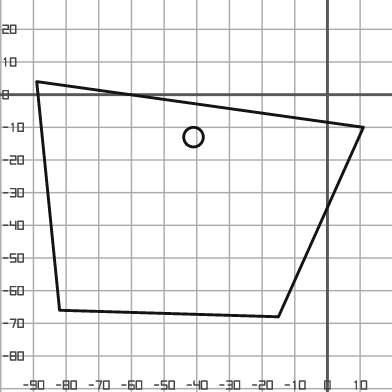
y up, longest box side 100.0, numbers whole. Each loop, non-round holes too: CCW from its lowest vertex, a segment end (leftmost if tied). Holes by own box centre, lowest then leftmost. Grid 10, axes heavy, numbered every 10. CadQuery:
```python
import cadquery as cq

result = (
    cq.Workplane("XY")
    .moveTo(-15.0, -68.0)
    .lineTo(11.0, -10.0)
    .lineTo(-89.0, 4.0)
    .lineTo(-82.0, -66.0)
    .close()
    .moveTo(-41.0, -13.0)
    .circle(3.0)
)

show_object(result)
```